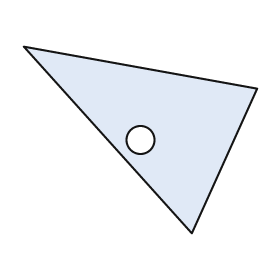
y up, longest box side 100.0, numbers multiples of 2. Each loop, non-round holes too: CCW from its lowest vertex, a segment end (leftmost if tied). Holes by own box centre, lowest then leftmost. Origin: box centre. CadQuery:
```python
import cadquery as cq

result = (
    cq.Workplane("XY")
    .moveTo(22.0, -40.0)
    .lineTo(50.0, 22.0)
    .lineTo(-50.0, 40.0)
    .close()
    .moveTo(0.0, 0.0)
    .circle(6.0)
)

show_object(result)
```